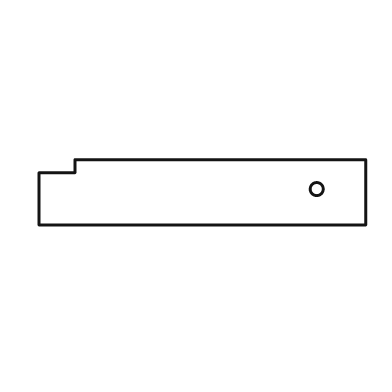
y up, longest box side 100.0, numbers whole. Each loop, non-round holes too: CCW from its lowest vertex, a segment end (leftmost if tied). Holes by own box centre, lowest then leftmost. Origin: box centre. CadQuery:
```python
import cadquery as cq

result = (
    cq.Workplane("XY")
    .moveTo(-50.0, -10.0)
    .lineTo(50.0, -10.0)
    .lineTo(50.0, 10.0)
    .lineTo(-39.0, 10.0)
    .lineTo(-39.0, 6.0)
    .lineTo(-50.0, 6.0)
    .close()
    .moveTo(35.0, 1.0)
    .circle(2.0)
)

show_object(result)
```